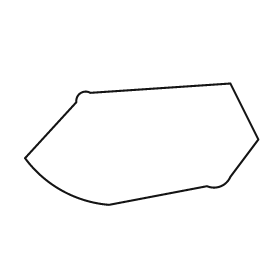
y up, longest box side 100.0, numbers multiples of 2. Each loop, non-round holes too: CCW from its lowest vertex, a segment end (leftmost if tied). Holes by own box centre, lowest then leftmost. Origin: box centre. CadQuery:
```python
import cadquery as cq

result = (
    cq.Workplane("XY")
    .moveTo(-14.0, -26.0)
    .lineTo(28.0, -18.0)
    .threePointArc((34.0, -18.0), (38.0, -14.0))
    .lineTo(50.0, 2.0)
    .lineTo(38.0, 26.0)
    .lineTo(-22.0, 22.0)
    .threePointArc((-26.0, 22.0), (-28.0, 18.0))
    .lineTo(-50.0, -6.0)
    .threePointArc((-34.0, -20.0), (-14.0, -26.0))
    .close()
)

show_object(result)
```